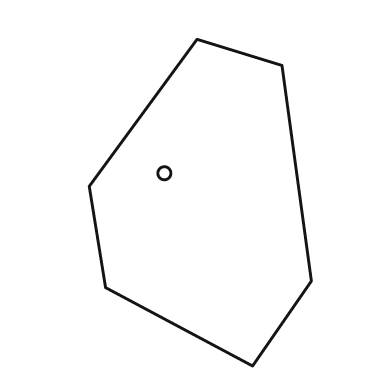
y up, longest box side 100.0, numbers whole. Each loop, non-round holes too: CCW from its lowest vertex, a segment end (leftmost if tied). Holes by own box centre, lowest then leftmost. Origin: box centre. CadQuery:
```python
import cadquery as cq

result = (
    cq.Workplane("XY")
    .moveTo(16.0, -50.0)
    .lineTo(34.0, -24.0)
    .lineTo(25.0, 42.0)
    .lineTo(-1.0, 50.0)
    .lineTo(-34.0, 5.0)
    .lineTo(-29.0, -26.0)
    .close()
    .moveTo(-11.0, 9.0)
    .circle(2.0)
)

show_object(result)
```